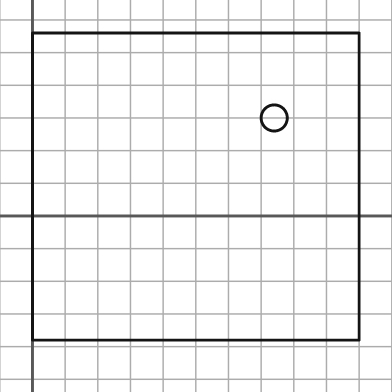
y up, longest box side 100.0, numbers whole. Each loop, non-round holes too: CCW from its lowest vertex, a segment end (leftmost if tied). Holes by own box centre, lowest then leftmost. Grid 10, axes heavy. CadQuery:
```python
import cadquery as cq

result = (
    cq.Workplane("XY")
    .moveTo(0.0, -38.0)
    .lineTo(100.0, -38.0)
    .lineTo(100.0, 56.0)
    .lineTo(0.0, 56.0)
    .close()
    .moveTo(74.0, 30.0)
    .circle(4.0)
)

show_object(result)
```